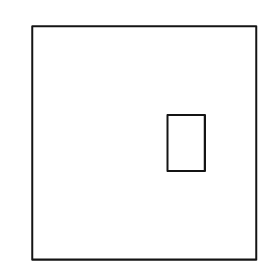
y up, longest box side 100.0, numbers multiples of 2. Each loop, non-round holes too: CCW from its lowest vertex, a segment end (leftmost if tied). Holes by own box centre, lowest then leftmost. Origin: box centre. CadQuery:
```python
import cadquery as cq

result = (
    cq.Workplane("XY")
    .moveTo(-48.0, -50.0)
    .lineTo(48.0, -50.0)
    .lineTo(48.0, 50.0)
    .lineTo(-48.0, 50.0)
    .close()
    .moveTo(10.0, -12.0)
    .lineTo(26.0, -12.0)
    .lineTo(26.0, 12.0)
    .lineTo(10.0, 12.0)
    .close()
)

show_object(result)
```